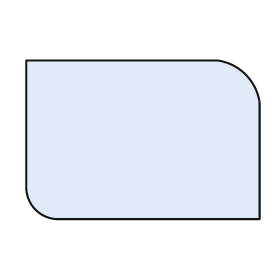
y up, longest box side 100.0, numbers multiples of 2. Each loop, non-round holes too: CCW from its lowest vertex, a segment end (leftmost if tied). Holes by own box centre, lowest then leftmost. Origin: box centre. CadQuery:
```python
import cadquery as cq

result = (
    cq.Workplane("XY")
    .moveTo(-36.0, -34.0)
    .lineTo(50.0, -34.0)
    .lineTo(50.0, 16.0)
    .threePointArc((44.0, 28.0), (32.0, 34.0))
    .lineTo(-50.0, 34.0)
    .lineTo(-50.0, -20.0)
    .threePointArc((-46.0, -30.0), (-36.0, -34.0))
    .close()
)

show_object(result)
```